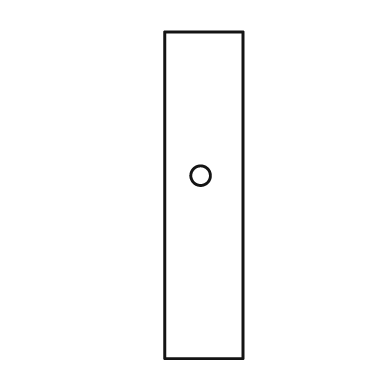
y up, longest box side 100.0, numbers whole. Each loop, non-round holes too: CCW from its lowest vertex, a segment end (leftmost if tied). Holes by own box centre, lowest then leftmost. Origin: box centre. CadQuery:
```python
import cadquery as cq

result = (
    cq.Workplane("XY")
    .moveTo(-12.0, -50.0)
    .lineTo(12.0, -50.0)
    .lineTo(12.0, 50.0)
    .lineTo(-12.0, 50.0)
    .close()
    .moveTo(-1.0, 6.0)
    .circle(3.0)
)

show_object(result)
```